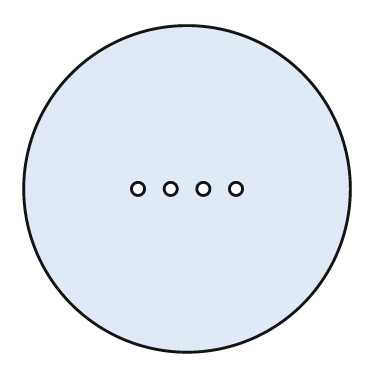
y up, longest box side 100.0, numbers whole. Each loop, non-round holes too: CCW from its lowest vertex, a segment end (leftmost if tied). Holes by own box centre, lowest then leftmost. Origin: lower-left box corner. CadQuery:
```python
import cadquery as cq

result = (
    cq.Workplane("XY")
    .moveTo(50.0, 50.0)
    .circle(50.0)
    .moveTo(35.0, 50.0)
    .circle(2.0)
    .moveTo(45.0, 50.0)
    .circle(2.0)
    .moveTo(55.0, 50.0)
    .circle(2.0)
    .moveTo(65.0, 50.0)
    .circle(2.0)
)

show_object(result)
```